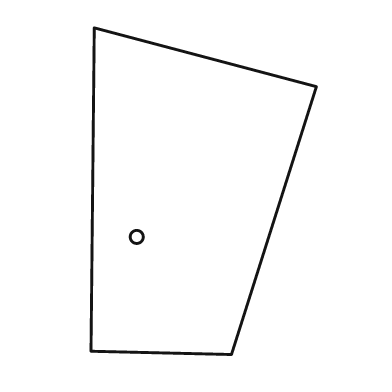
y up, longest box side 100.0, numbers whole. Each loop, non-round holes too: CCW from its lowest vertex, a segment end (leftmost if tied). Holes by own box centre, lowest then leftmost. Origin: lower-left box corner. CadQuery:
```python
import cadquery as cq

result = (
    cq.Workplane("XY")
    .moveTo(43.0, 0.0)
    .lineTo(69.0, 82.0)
    .lineTo(1.0, 100.0)
    .lineTo(0.0, 1.0)
    .close()
    .moveTo(14.0, 36.0)
    .circle(2.0)
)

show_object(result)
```